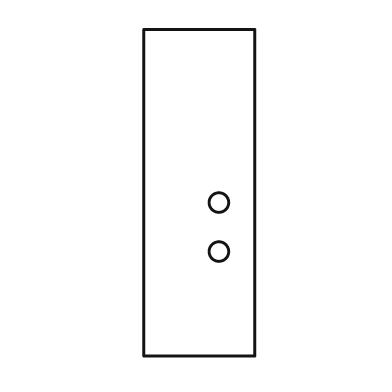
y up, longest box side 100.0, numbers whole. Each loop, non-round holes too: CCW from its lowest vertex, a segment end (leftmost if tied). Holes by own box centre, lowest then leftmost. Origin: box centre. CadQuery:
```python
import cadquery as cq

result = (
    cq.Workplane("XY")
    .moveTo(-17.0, -50.0)
    .lineTo(17.0, -50.0)
    .lineTo(17.0, 50.0)
    .lineTo(-17.0, 50.0)
    .close()
    .moveTo(6.0, -18.0)
    .circle(3.0)
    .moveTo(6.0, -3.0)
    .circle(3.0)
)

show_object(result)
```